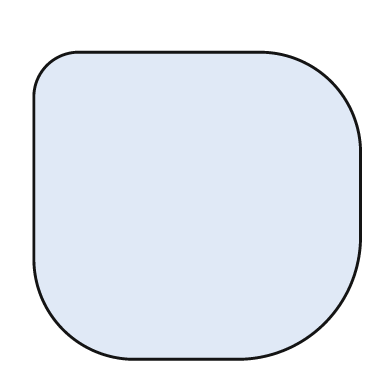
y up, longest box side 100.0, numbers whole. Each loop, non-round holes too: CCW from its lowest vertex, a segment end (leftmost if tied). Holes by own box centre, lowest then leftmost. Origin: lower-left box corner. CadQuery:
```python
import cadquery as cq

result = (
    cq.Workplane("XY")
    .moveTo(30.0, 0.0)
    .lineTo(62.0, 0.0)
    .threePointArc((89.0, 11.0), (100.0, 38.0))
    .lineTo(100.0, 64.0)
    .threePointArc((91.0, 85.0), (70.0, 94.0))
    .lineTo(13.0, 94.0)
    .threePointArc((4.0, 90.0), (0.0, 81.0))
    .lineTo(0.0, 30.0)
    .threePointArc((9.0, 9.0), (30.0, 0.0))
    .close()
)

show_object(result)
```